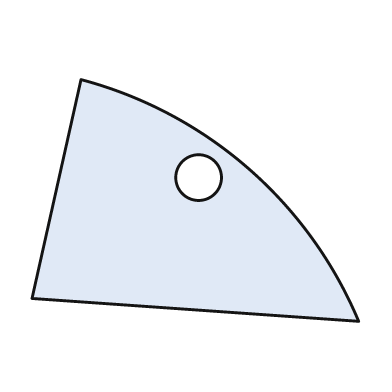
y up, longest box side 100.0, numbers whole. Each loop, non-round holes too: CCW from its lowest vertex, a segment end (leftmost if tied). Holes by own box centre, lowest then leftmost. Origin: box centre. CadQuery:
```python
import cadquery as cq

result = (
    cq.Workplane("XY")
    .moveTo(50.0, -37.0)
    .threePointArc((16.0, 10.0), (-35.0, 37.0))
    .lineTo(-50.0, -30.0)
    .close()
    .moveTo(1.0, 7.0)
    .circle(7.0)
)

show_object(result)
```